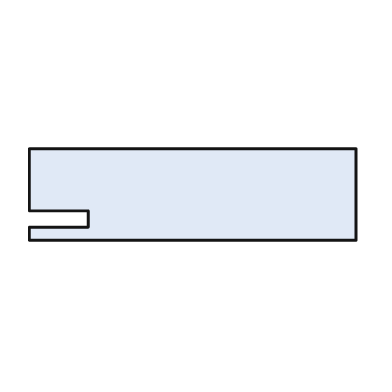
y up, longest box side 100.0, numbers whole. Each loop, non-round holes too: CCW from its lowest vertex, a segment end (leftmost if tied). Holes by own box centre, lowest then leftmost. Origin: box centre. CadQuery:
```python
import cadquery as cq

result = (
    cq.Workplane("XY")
    .moveTo(-50.0, -14.0)
    .lineTo(50.0, -14.0)
    .lineTo(50.0, 14.0)
    .lineTo(-50.0, 14.0)
    .lineTo(-50.0, -5.0)
    .lineTo(-32.0, -5.0)
    .lineTo(-32.0, -10.0)
    .lineTo(-50.0, -10.0)
    .close()
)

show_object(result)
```